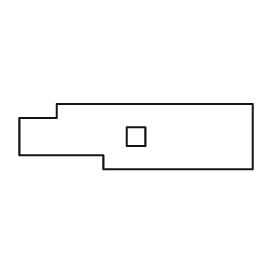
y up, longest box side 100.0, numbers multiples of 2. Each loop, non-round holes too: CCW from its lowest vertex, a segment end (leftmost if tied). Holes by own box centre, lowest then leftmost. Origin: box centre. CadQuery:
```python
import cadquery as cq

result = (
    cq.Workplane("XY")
    .moveTo(-14.0, -14.0)
    .lineTo(50.0, -14.0)
    .lineTo(50.0, 14.0)
    .lineTo(-34.0, 14.0)
    .lineTo(-34.0, 8.0)
    .lineTo(-50.0, 8.0)
    .lineTo(-50.0, -8.0)
    .lineTo(-14.0, -8.0)
    .close()
    .moveTo(-4.0, -4.0)
    .lineTo(4.0, -4.0)
    .lineTo(4.0, 4.0)
    .lineTo(-4.0, 4.0)
    .close()
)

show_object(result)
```